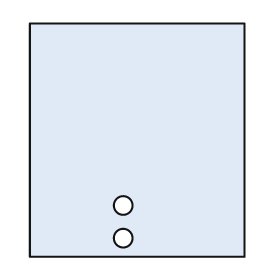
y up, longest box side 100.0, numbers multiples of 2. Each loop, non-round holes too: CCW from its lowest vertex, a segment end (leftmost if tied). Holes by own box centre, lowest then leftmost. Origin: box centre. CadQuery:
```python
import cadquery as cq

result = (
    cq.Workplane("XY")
    .moveTo(-46.0, -50.0)
    .lineTo(46.0, -50.0)
    .lineTo(46.0, 50.0)
    .lineTo(-46.0, 50.0)
    .close()
    .moveTo(-6.0, -42.0)
    .circle(4.0)
    .moveTo(-6.0, -28.0)
    .circle(4.0)
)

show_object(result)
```